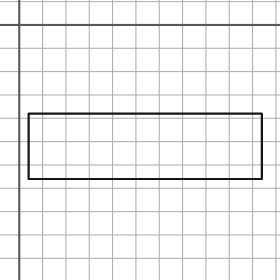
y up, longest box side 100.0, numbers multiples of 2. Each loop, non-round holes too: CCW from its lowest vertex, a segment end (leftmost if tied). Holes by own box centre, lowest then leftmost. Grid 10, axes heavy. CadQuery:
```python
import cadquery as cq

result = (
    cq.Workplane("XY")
    .moveTo(4.0, -66.0)
    .lineTo(104.0, -66.0)
    .lineTo(104.0, -38.0)
    .lineTo(4.0, -38.0)
    .close()
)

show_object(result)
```